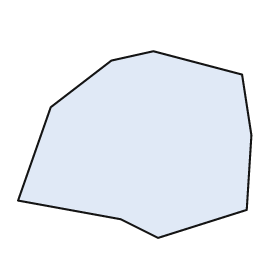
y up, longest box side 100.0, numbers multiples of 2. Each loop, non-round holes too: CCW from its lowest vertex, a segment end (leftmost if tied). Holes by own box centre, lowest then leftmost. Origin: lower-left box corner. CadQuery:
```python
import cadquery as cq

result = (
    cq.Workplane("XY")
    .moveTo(60.0, 0.0)
    .lineTo(98.0, 12.0)
    .lineTo(100.0, 44.0)
    .lineTo(96.0, 70.0)
    .lineTo(58.0, 80.0)
    .lineTo(40.0, 76.0)
    .lineTo(14.0, 56.0)
    .lineTo(0.0, 16.0)
    .lineTo(44.0, 8.0)
    .close()
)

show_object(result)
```